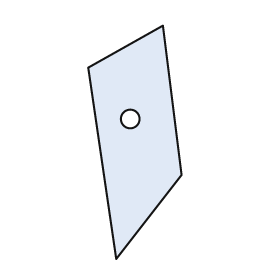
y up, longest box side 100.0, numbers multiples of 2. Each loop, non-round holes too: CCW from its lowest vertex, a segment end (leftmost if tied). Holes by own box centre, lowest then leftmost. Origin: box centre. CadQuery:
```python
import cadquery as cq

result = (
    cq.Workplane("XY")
    .moveTo(-8.0, -50.0)
    .lineTo(20.0, -14.0)
    .lineTo(12.0, 50.0)
    .lineTo(-20.0, 32.0)
    .close()
    .moveTo(-2.0, 10.0)
    .circle(4.0)
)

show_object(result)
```